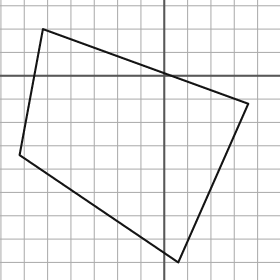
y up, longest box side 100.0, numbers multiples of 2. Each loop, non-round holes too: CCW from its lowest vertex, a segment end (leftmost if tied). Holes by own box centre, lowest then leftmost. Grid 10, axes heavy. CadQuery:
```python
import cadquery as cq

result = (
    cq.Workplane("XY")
    .moveTo(6.0, -80.0)
    .lineTo(36.0, -12.0)
    .lineTo(-52.0, 20.0)
    .lineTo(-62.0, -34.0)
    .close()
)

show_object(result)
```